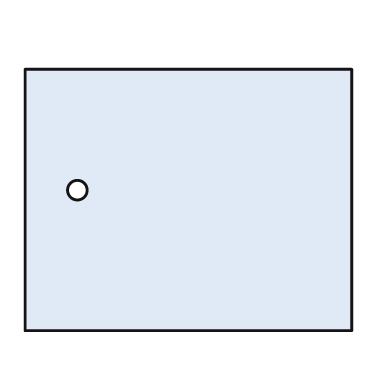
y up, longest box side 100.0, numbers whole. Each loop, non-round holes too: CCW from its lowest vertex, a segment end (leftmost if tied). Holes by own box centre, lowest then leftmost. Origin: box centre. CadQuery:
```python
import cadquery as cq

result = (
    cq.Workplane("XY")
    .moveTo(-50.0, -40.0)
    .lineTo(50.0, -40.0)
    .lineTo(50.0, 40.0)
    .lineTo(-50.0, 40.0)
    .close()
    .moveTo(-34.0, 3.0)
    .circle(3.0)
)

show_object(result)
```